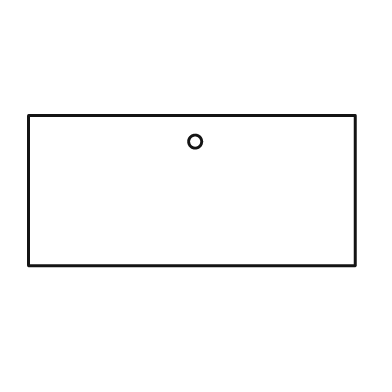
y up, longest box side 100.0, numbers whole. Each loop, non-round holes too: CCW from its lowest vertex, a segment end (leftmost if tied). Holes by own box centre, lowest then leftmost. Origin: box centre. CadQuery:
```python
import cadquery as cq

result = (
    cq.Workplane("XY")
    .moveTo(-50.0, -23.0)
    .lineTo(50.0, -23.0)
    .lineTo(50.0, 23.0)
    .lineTo(-50.0, 23.0)
    .close()
    .moveTo(1.0, 15.0)
    .circle(2.0)
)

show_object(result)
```